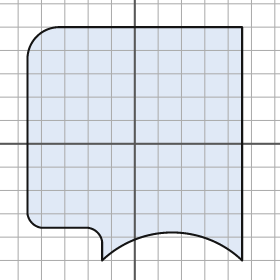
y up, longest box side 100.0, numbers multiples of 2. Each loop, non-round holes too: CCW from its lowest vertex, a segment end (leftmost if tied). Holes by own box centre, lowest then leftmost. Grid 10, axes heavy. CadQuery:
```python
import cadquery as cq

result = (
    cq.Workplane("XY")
    .moveTo(-14.0, -50.0)
    .threePointArc((16.0, -38.0), (46.0, -50.0))
    .lineTo(46.0, 50.0)
    .lineTo(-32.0, 50.0)
    .threePointArc((-42.0, 46.0), (-46.0, 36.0))
    .lineTo(-46.0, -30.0)
    .threePointArc((-44.0, -34.0), (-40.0, -36.0))
    .lineTo(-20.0, -36.0)
    .threePointArc((-16.0, -38.0), (-14.0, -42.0))
    .close()
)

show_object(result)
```